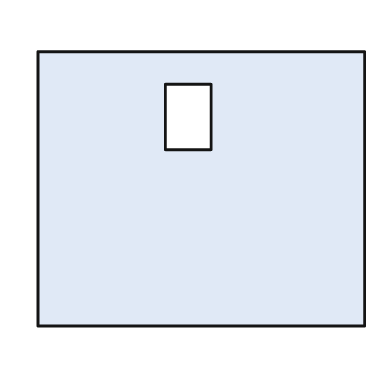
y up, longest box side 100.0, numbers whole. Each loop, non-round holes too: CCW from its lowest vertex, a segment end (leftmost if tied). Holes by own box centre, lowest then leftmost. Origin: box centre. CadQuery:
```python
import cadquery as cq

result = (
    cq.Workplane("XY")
    .moveTo(-50.0, -42.0)
    .lineTo(50.0, -42.0)
    .lineTo(50.0, 42.0)
    .lineTo(-50.0, 42.0)
    .close()
    .moveTo(-11.0, 12.0)
    .lineTo(3.0, 12.0)
    .lineTo(3.0, 32.0)
    .lineTo(-11.0, 32.0)
    .close()
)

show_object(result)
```